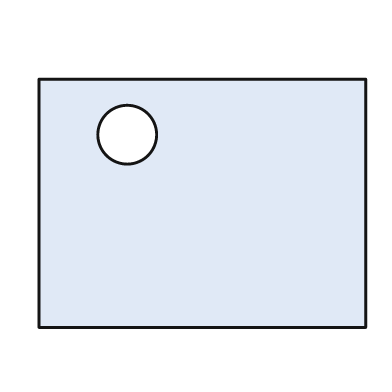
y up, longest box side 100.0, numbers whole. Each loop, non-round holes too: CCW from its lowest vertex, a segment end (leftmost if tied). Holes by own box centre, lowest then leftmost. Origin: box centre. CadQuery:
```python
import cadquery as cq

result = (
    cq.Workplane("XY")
    .moveTo(-50.0, -38.0)
    .lineTo(50.0, -38.0)
    .lineTo(50.0, 38.0)
    .lineTo(-50.0, 38.0)
    .close()
    .moveTo(-23.0, 21.0)
    .circle(9.0)
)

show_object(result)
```